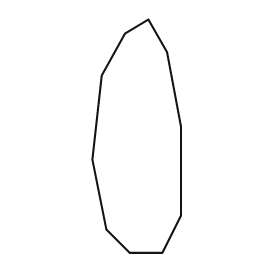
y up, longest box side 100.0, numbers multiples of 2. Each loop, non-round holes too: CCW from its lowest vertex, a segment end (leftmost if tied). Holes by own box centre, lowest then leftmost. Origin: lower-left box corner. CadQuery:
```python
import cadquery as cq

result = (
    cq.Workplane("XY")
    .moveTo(16.0, 0.0)
    .lineTo(30.0, 0.0)
    .lineTo(38.0, 16.0)
    .lineTo(38.0, 54.0)
    .lineTo(32.0, 86.0)
    .lineTo(24.0, 100.0)
    .lineTo(14.0, 94.0)
    .lineTo(4.0, 76.0)
    .lineTo(0.0, 40.0)
    .lineTo(6.0, 10.0)
    .close()
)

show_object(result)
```